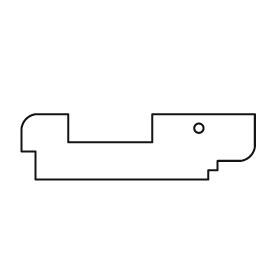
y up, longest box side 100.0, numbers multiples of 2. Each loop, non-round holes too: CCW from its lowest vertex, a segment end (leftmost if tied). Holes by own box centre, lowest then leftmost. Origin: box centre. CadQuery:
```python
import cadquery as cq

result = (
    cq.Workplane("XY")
    .moveTo(-44.0, -14.0)
    .lineTo(30.0, -14.0)
    .lineTo(30.0, -10.0)
    .lineTo(34.0, -10.0)
    .lineTo(34.0, -6.0)
    .lineTo(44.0, -6.0)
    .threePointArc((48.0, -4.0), (50.0, 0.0))
    .lineTo(50.0, 14.0)
    .lineTo(6.0, 14.0)
    .lineTo(6.0, 2.0)
    .lineTo(-30.0, 2.0)
    .lineTo(-30.0, 14.0)
    .lineTo(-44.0, 14.0)
    .threePointArc((-48.0, 12.0), (-50.0, 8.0))
    .lineTo(-50.0, -2.0)
    .lineTo(-44.0, -2.0)
    .close()
    .moveTo(26.0, 8.0)
    .circle(2.0)
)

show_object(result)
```